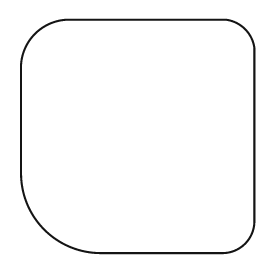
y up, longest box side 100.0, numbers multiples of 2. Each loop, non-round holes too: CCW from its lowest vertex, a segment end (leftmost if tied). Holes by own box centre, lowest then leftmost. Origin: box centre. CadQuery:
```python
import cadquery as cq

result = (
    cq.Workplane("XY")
    .moveTo(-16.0, -50.0)
    .lineTo(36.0, -50.0)
    .threePointArc((46.0, -46.0), (50.0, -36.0))
    .lineTo(50.0, 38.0)
    .threePointArc((46.0, 46.0), (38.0, 50.0))
    .lineTo(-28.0, 50.0)
    .threePointArc((-44.0, 44.0), (-50.0, 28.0))
    .lineTo(-50.0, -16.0)
    .threePointArc((-40.0, -40.0), (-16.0, -50.0))
    .close()
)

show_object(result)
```